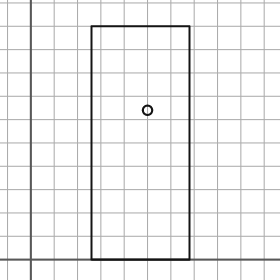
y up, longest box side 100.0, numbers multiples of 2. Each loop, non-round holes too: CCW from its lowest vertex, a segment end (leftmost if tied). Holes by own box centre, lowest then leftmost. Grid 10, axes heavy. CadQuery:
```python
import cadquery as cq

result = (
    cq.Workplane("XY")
    .moveTo(26.0, 0.0)
    .lineTo(68.0, 0.0)
    .lineTo(68.0, 100.0)
    .lineTo(26.0, 100.0)
    .close()
    .moveTo(50.0, 64.0)
    .circle(2.0)
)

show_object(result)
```